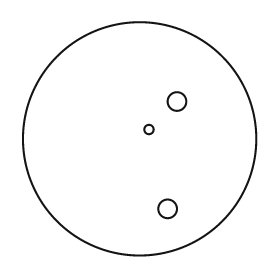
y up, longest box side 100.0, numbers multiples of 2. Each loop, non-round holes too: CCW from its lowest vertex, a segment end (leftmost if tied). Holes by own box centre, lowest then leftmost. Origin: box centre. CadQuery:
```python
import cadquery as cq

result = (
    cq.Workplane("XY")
    .moveTo(0.0, 0.0)
    .circle(50.0)
    .moveTo(12.0, -30.0)
    .circle(4.0)
    .moveTo(4.0, 4.0)
    .circle(2.0)
    .moveTo(16.0, 16.0)
    .circle(4.0)
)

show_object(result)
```